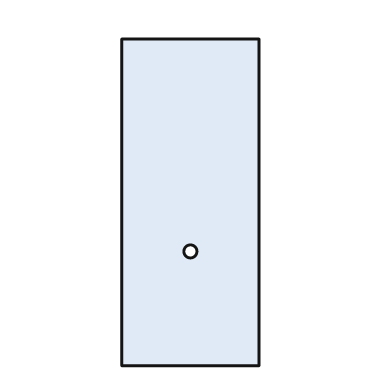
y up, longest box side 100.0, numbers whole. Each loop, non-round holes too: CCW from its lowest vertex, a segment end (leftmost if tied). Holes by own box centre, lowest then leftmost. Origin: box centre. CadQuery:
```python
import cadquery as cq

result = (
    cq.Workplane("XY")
    .moveTo(-21.0, -50.0)
    .lineTo(21.0, -50.0)
    .lineTo(21.0, 50.0)
    .lineTo(-21.0, 50.0)
    .close()
    .moveTo(0.0, -15.0)
    .circle(2.0)
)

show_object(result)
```